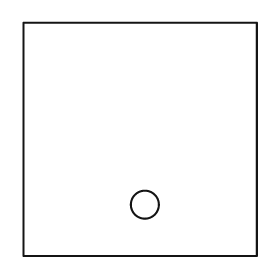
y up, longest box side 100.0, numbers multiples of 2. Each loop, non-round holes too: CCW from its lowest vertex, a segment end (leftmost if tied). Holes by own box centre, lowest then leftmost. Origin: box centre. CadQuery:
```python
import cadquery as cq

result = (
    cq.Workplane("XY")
    .moveTo(-50.0, -50.0)
    .lineTo(50.0, -50.0)
    .lineTo(50.0, 50.0)
    .lineTo(-50.0, 50.0)
    .close()
    .moveTo(2.0, -28.0)
    .circle(6.0)
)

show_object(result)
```